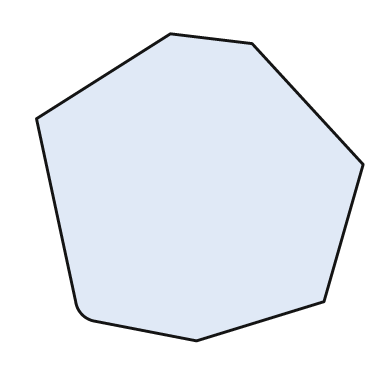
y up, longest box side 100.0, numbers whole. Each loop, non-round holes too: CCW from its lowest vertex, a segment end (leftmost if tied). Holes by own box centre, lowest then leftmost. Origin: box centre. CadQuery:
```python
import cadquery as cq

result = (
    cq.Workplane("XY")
    .moveTo(-1.0, -47.0)
    .lineTo(38.0, -35.0)
    .lineTo(50.0, 7.0)
    .lineTo(16.0, 44.0)
    .lineTo(-9.0, 47.0)
    .lineTo(-50.0, 21.0)
    .lineTo(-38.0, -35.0)
    .threePointArc((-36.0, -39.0), (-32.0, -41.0))
    .close()
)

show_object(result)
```